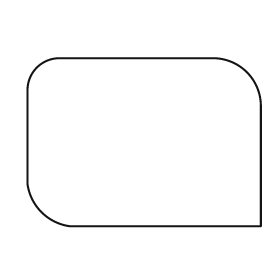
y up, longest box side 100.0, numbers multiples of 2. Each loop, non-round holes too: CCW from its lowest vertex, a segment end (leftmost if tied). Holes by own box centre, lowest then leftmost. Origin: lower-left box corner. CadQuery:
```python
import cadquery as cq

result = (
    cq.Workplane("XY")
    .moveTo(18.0, 0.0)
    .lineTo(100.0, 0.0)
    .lineTo(100.0, 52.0)
    .threePointArc((94.0, 66.0), (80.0, 72.0))
    .lineTo(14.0, 72.0)
    .threePointArc((4.0, 68.0), (0.0, 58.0))
    .lineTo(0.0, 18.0)
    .threePointArc((6.0, 6.0), (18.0, 0.0))
    .close()
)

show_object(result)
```